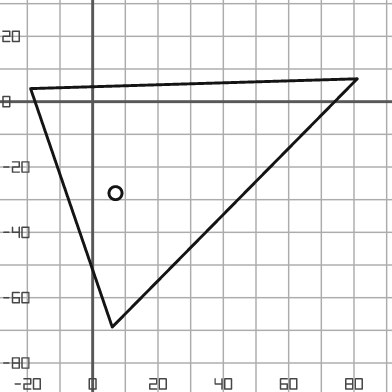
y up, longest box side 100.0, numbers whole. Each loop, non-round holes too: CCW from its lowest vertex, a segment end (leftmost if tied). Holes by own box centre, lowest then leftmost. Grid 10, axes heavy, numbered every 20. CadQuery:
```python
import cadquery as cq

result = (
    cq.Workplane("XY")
    .moveTo(6.0, -69.0)
    .lineTo(81.0, 7.0)
    .lineTo(-19.0, 4.0)
    .close()
    .moveTo(7.0, -28.0)
    .circle(2.0)
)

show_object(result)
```